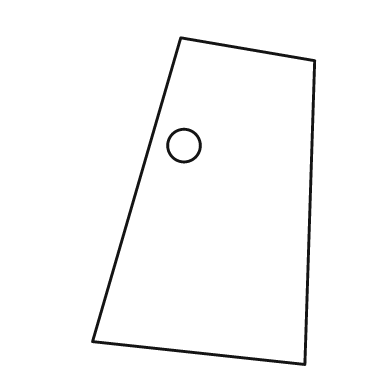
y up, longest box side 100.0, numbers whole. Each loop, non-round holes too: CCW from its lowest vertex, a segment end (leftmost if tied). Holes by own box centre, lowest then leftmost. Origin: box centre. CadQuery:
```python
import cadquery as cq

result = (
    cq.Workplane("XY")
    .moveTo(31.0, -50.0)
    .lineTo(34.0, 43.0)
    .lineTo(-7.0, 50.0)
    .lineTo(-34.0, -43.0)
    .close()
    .moveTo(-6.0, 17.0)
    .circle(5.0)
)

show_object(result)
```